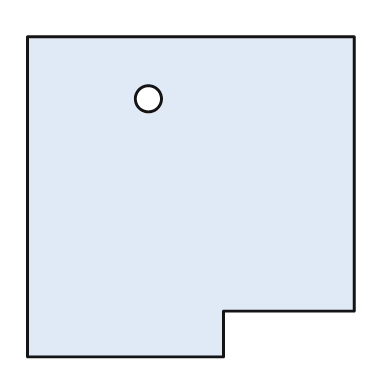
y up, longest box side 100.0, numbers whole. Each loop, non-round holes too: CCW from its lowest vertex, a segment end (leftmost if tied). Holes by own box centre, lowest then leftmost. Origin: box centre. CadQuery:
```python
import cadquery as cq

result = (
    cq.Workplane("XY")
    .moveTo(-50.0, -49.0)
    .lineTo(10.0, -49.0)
    .lineTo(10.0, -35.0)
    .lineTo(50.0, -35.0)
    .lineTo(50.0, 49.0)
    .lineTo(-50.0, 49.0)
    .close()
    .moveTo(-13.0, 30.0)
    .circle(4.0)
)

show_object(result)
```